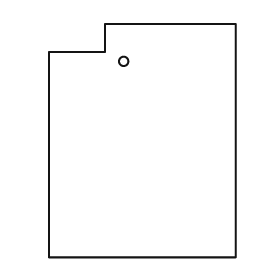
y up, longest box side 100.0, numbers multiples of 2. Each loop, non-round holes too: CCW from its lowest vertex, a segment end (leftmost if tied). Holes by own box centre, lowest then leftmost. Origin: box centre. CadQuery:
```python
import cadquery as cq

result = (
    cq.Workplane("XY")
    .moveTo(-40.0, -50.0)
    .lineTo(40.0, -50.0)
    .lineTo(40.0, 50.0)
    .lineTo(-16.0, 50.0)
    .lineTo(-16.0, 38.0)
    .lineTo(-40.0, 38.0)
    .close()
    .moveTo(-8.0, 34.0)
    .circle(2.0)
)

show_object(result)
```